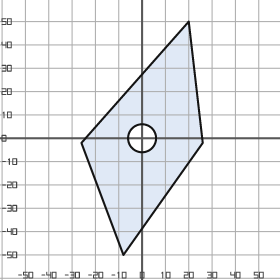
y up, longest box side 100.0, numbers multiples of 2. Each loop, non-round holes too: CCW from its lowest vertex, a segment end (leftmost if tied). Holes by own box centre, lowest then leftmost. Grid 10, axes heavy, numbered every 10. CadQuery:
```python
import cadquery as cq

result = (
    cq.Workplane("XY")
    .moveTo(-8.0, -50.0)
    .lineTo(26.0, -2.0)
    .lineTo(20.0, 50.0)
    .lineTo(-26.0, -2.0)
    .close()
    .moveTo(0.0, 0.0)
    .circle(6.0)
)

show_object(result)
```